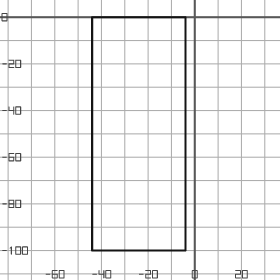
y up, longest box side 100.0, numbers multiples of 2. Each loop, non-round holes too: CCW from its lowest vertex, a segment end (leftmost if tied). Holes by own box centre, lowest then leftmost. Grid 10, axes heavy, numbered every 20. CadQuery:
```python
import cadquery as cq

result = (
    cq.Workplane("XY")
    .moveTo(-44.0, -100.0)
    .lineTo(-4.0, -100.0)
    .lineTo(-4.0, 0.0)
    .lineTo(-44.0, 0.0)
    .close()
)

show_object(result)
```